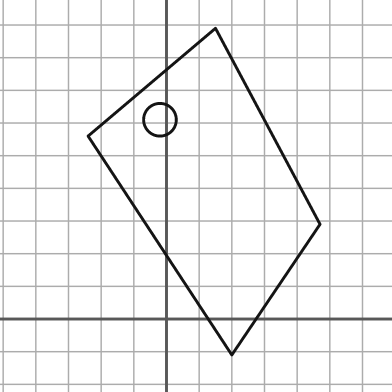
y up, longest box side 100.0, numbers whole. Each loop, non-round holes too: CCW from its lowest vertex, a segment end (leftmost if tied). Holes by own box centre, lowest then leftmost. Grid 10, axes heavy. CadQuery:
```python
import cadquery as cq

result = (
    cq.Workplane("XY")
    .moveTo(20.0, -11.0)
    .lineTo(47.0, 29.0)
    .lineTo(15.0, 89.0)
    .lineTo(-24.0, 56.0)
    .close()
    .moveTo(-2.0, 61.0)
    .circle(5.0)
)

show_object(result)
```